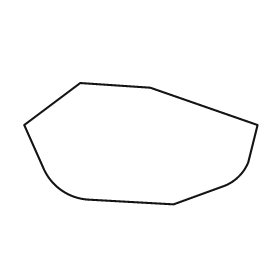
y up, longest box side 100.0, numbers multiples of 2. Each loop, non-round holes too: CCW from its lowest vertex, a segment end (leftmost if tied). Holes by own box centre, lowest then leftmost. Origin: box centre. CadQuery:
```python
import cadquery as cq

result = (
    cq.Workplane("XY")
    .moveTo(14.0, -26.0)
    .lineTo(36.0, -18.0)
    .threePointArc((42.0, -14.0), (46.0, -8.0))
    .lineTo(50.0, 8.0)
    .lineTo(4.0, 24.0)
    .lineTo(-26.0, 26.0)
    .lineTo(-50.0, 8.0)
    .lineTo(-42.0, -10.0)
    .threePointArc((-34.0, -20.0), (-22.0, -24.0))
    .close()
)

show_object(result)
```